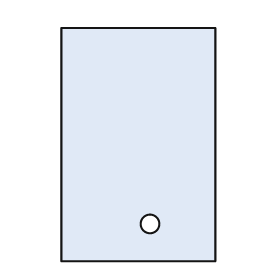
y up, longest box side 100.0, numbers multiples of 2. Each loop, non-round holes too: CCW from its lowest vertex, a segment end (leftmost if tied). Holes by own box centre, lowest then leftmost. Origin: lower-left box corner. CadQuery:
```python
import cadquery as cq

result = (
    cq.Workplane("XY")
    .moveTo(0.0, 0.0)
    .lineTo(66.0, 0.0)
    .lineTo(66.0, 100.0)
    .lineTo(0.0, 100.0)
    .close()
    .moveTo(38.0, 16.0)
    .circle(4.0)
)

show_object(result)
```